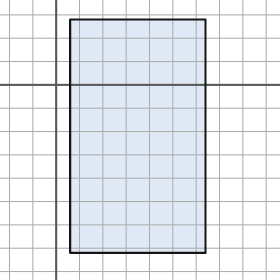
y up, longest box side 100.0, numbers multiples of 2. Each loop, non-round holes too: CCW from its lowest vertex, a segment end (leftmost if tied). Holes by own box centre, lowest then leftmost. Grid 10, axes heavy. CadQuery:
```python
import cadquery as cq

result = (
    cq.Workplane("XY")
    .moveTo(6.0, -72.0)
    .lineTo(64.0, -72.0)
    .lineTo(64.0, 28.0)
    .lineTo(6.0, 28.0)
    .close()
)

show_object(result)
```